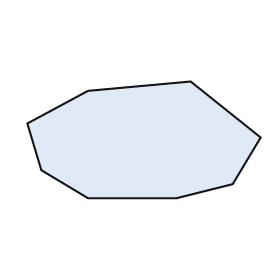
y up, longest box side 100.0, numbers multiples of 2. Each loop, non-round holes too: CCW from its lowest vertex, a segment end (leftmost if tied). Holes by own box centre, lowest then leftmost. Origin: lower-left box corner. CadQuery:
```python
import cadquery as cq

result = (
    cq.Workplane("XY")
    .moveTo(26.0, 0.0)
    .lineTo(64.0, 0.0)
    .lineTo(88.0, 6.0)
    .lineTo(100.0, 26.0)
    .lineTo(70.0, 50.0)
    .lineTo(26.0, 46.0)
    .lineTo(0.0, 32.0)
    .lineTo(6.0, 12.0)
    .close()
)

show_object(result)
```